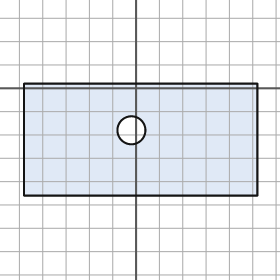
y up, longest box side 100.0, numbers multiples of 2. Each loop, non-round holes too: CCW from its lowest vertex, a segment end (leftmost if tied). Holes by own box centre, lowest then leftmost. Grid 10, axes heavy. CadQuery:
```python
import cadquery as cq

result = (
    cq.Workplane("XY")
    .moveTo(-48.0, -46.0)
    .lineTo(52.0, -46.0)
    .lineTo(52.0, 2.0)
    .lineTo(-48.0, 2.0)
    .close()
    .moveTo(-2.0, -18.0)
    .circle(6.0)
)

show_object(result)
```